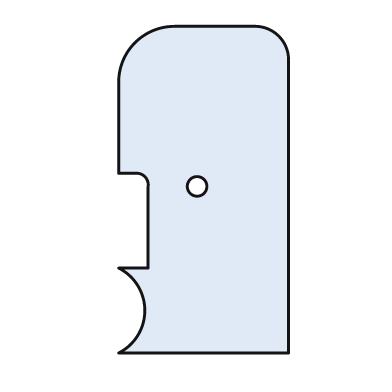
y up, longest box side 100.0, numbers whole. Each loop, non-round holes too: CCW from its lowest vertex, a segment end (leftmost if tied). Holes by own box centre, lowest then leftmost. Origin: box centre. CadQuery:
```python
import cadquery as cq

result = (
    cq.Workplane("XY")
    .moveTo(-26.0, -50.0)
    .lineTo(26.0, -50.0)
    .lineTo(26.0, 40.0)
    .threePointArc((23.0, 47.0), (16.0, 50.0))
    .lineTo(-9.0, 50.0)
    .threePointArc((-21.0, 45.0), (-26.0, 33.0))
    .lineTo(-26.0, 5.0)
    .lineTo(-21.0, 5.0)
    .threePointArc((-18.0, 4.0), (-17.0, 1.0))
    .lineTo(-17.0, -24.0)
    .lineTo(-26.0, -24.0)
    .threePointArc((-18.0, -37.0), (-26.0, -50.0))
    .close()
    .moveTo(-2.0, 1.0)
    .circle(3.0)
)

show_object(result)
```